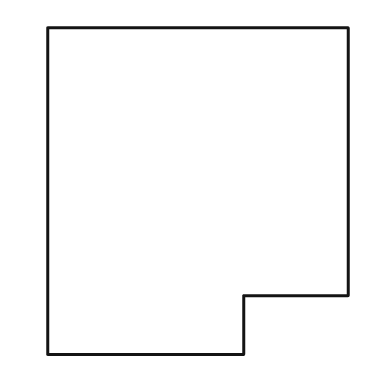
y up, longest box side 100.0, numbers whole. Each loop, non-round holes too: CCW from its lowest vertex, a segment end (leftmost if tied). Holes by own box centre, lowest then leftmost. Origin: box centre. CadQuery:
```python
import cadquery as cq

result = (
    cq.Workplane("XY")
    .moveTo(-46.0, -50.0)
    .lineTo(14.0, -50.0)
    .lineTo(14.0, -32.0)
    .lineTo(46.0, -32.0)
    .lineTo(46.0, 50.0)
    .lineTo(-46.0, 50.0)
    .close()
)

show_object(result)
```